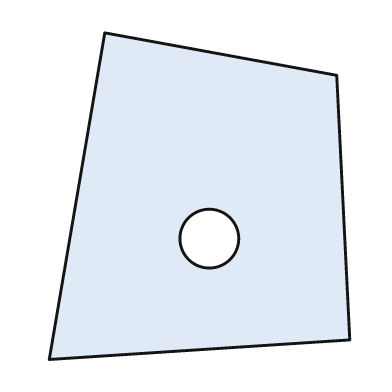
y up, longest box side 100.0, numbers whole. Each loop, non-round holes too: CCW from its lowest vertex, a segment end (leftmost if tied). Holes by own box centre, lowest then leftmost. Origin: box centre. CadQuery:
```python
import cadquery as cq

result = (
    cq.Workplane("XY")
    .moveTo(-46.0, -50.0)
    .lineTo(46.0, -44.0)
    .lineTo(42.0, 37.0)
    .lineTo(-29.0, 50.0)
    .close()
    .moveTo(3.0, -13.0)
    .circle(9.0)
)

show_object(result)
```